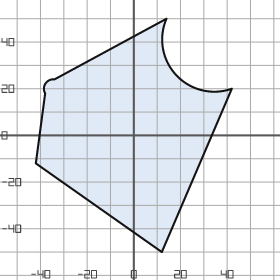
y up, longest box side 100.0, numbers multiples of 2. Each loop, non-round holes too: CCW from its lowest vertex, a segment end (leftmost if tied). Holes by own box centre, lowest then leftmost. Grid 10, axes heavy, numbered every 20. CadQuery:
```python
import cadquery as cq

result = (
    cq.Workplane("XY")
    .moveTo(12.0, -50.0)
    .lineTo(42.0, 20.0)
    .threePointArc((18.0, 26.0), (14.0, 50.0))
    .lineTo(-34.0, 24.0)
    .threePointArc((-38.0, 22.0), (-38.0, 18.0))
    .lineTo(-42.0, -12.0)
    .close()
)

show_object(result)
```